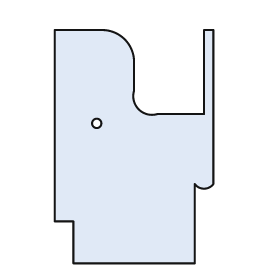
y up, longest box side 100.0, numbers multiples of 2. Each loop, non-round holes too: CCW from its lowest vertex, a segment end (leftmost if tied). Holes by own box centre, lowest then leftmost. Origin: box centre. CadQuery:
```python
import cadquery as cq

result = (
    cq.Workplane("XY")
    .moveTo(-26.0, -50.0)
    .lineTo(26.0, -50.0)
    .lineTo(26.0, -16.0)
    .threePointArc((30.0, -18.0), (34.0, -16.0))
    .lineTo(34.0, 50.0)
    .lineTo(30.0, 50.0)
    .lineTo(30.0, 14.0)
    .lineTo(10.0, 14.0)
    .threePointArc((2.0, 16.0), (0.0, 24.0))
    .lineTo(0.0, 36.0)
    .threePointArc((-4.0, 46.0), (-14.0, 50.0))
    .lineTo(-34.0, 50.0)
    .lineTo(-34.0, -32.0)
    .lineTo(-26.0, -32.0)
    .close()
    .moveTo(-16.0, 10.0)
    .circle(2.0)
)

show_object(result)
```